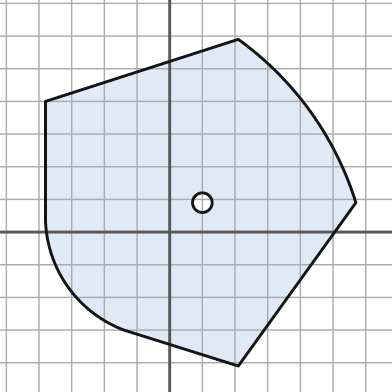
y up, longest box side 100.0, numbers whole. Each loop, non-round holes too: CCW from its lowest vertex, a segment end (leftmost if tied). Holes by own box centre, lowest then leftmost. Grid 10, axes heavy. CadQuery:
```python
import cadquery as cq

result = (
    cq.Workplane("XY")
    .moveTo(21.0, -41.0)
    .lineTo(57.0, 9.0)
    .threePointArc((43.0, 37.0), (21.0, 59.0))
    .lineTo(-38.0, 40.0)
    .lineTo(-38.0, 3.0)
    .threePointArc((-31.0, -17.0), (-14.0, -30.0))
    .close()
    .moveTo(10.0, 9.0)
    .circle(3.0)
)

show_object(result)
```